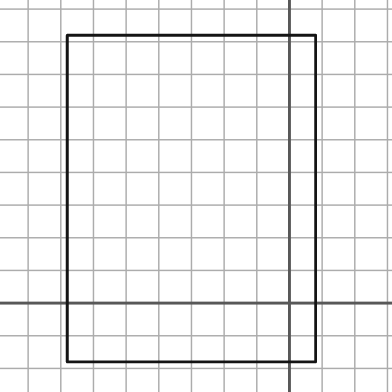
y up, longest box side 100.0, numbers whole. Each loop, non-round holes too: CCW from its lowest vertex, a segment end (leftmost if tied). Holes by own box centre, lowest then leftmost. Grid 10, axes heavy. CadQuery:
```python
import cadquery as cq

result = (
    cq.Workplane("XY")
    .moveTo(-68.0, -18.0)
    .lineTo(8.0, -18.0)
    .lineTo(8.0, 82.0)
    .lineTo(-68.0, 82.0)
    .close()
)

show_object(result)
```